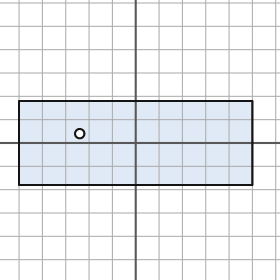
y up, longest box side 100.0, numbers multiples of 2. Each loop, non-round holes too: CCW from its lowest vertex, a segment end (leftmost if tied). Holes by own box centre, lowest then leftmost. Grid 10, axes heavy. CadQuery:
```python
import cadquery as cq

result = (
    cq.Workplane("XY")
    .moveTo(-50.0, -18.0)
    .lineTo(50.0, -18.0)
    .lineTo(50.0, 18.0)
    .lineTo(-50.0, 18.0)
    .close()
    .moveTo(-24.0, 4.0)
    .circle(2.0)
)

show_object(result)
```